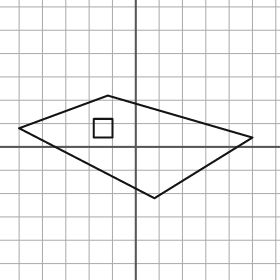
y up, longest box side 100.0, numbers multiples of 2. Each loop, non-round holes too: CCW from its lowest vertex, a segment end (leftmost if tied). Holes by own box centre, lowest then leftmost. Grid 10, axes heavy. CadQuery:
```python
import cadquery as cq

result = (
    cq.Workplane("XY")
    .moveTo(8.0, -22.0)
    .lineTo(50.0, 4.0)
    .lineTo(-12.0, 22.0)
    .lineTo(-50.0, 8.0)
    .close()
    .moveTo(-18.0, 4.0)
    .lineTo(-10.0, 4.0)
    .lineTo(-10.0, 12.0)
    .lineTo(-18.0, 12.0)
    .close()
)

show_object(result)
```